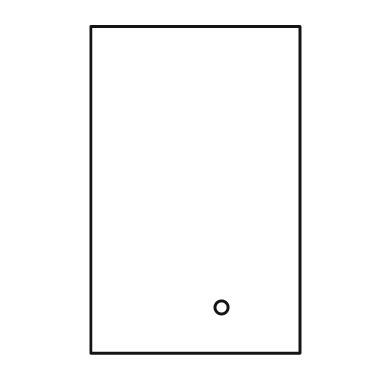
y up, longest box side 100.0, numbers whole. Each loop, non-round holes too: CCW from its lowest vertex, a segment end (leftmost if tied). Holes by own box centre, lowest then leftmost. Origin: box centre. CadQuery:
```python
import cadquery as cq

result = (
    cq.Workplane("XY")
    .moveTo(-32.0, -50.0)
    .lineTo(32.0, -50.0)
    .lineTo(32.0, 50.0)
    .lineTo(-32.0, 50.0)
    .close()
    .moveTo(8.0, -36.0)
    .circle(2.0)
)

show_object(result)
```